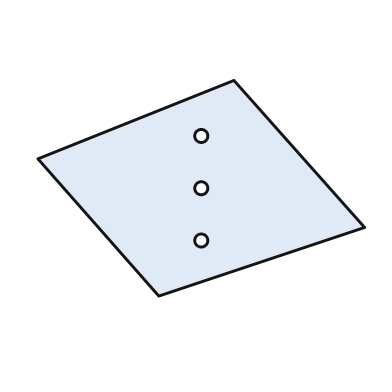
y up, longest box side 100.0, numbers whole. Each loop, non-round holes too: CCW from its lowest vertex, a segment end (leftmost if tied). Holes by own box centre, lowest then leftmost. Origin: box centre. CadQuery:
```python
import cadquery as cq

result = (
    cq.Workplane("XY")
    .moveTo(-13.0, -33.0)
    .lineTo(50.0, -12.0)
    .lineTo(10.0, 33.0)
    .lineTo(-50.0, 9.0)
    .close()
    .moveTo(0.0, -16.0)
    .circle(2.0)
    .moveTo(0.0, 0.0)
    .circle(2.0)
    .moveTo(0.0, 16.0)
    .circle(2.0)
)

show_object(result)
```